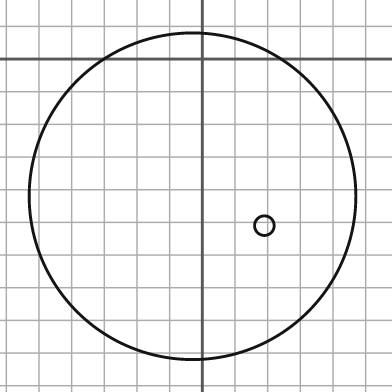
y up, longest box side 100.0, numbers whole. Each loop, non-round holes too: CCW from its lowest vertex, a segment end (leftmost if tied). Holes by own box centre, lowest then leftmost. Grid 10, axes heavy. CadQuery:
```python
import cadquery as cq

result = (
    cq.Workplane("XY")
    .moveTo(-3.0, -42.0)
    .circle(50.0)
    .moveTo(19.0, -51.0)
    .circle(3.0)
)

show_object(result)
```